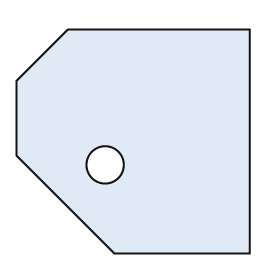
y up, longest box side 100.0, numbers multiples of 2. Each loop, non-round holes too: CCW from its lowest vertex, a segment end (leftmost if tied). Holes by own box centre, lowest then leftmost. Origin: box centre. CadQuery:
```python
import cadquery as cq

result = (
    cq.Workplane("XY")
    .moveTo(-8.0, -48.0)
    .lineTo(50.0, -48.0)
    .lineTo(50.0, 48.0)
    .lineTo(-28.0, 48.0)
    .lineTo(-50.0, 26.0)
    .lineTo(-50.0, -6.0)
    .close()
    .moveTo(-12.0, -10.0)
    .circle(8.0)
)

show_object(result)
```